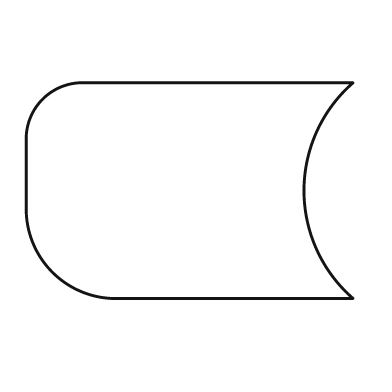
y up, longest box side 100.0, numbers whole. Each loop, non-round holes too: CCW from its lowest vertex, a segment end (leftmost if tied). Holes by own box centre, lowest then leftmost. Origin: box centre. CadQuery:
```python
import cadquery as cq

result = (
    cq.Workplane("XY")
    .moveTo(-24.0, -33.0)
    .lineTo(50.0, -33.0)
    .threePointArc((35.0, 0.0), (50.0, 33.0))
    .lineTo(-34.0, 33.0)
    .threePointArc((-45.0, 28.0), (-50.0, 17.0))
    .lineTo(-50.0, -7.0)
    .threePointArc((-42.0, -25.0), (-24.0, -33.0))
    .close()
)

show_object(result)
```